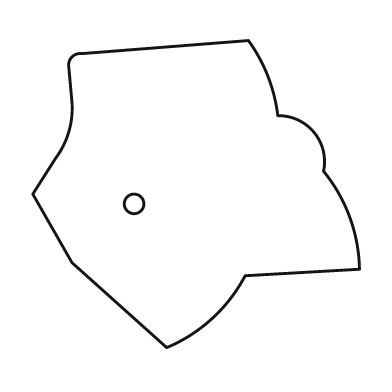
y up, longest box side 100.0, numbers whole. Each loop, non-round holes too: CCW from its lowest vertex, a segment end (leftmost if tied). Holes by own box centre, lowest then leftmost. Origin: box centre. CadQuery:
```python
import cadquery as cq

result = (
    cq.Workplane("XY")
    .moveTo(-9.0, -47.0)
    .threePointArc((5.0, -38.0), (15.0, -25.0))
    .lineTo(50.0, -23.0)
    .threePointArc((47.0, -7.0), (39.0, 7.0))
    .threePointArc((36.0, 19.0), (25.0, 24.0))
    .threePointArc((22.0, 36.0), (16.0, 47.0))
    .lineTo(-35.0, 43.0)
    .threePointArc((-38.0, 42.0), (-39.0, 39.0))
    .lineTo(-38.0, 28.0)
    .threePointArc((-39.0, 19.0), (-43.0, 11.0))
    .lineTo(-50.0, 0.0)
    .lineTo(-38.0, -21.0)
    .close()
    .moveTo(-19.0, -3.0)
    .circle(3.0)
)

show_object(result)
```